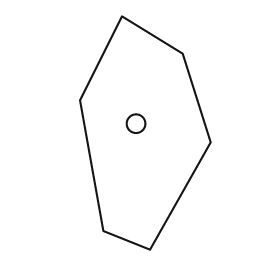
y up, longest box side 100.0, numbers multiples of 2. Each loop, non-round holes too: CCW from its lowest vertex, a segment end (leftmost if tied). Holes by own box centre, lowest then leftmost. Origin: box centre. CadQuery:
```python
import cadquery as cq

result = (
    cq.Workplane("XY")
    .moveTo(2.0, -50.0)
    .lineTo(28.0, -4.0)
    .lineTo(16.0, 34.0)
    .lineTo(-10.0, 50.0)
    .lineTo(-28.0, 14.0)
    .lineTo(-18.0, -42.0)
    .close()
    .moveTo(-4.0, 4.0)
    .circle(4.0)
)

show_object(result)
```